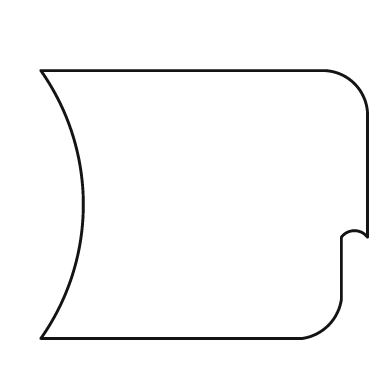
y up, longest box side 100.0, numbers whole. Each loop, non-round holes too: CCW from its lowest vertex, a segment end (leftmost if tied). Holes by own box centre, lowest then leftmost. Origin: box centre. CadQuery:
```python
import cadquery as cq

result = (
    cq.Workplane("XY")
    .moveTo(-50.0, -41.0)
    .lineTo(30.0, -41.0)
    .threePointArc((38.0, -37.0), (42.0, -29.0))
    .lineTo(42.0, -10.0)
    .threePointArc((46.0, -8.0), (50.0, -10.0))
    .lineTo(50.0, 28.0)
    .threePointArc((46.0, 37.0), (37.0, 41.0))
    .lineTo(-50.0, 41.0)
    .threePointArc((-37.0, 0.0), (-50.0, -41.0))
    .close()
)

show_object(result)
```